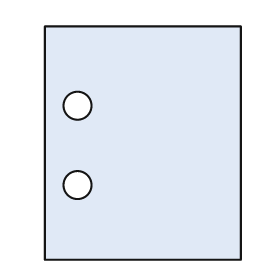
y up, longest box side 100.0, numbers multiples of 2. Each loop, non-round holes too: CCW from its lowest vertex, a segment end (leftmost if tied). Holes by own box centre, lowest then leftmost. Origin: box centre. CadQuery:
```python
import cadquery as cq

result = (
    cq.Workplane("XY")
    .moveTo(-42.0, -50.0)
    .lineTo(42.0, -50.0)
    .lineTo(42.0, 50.0)
    .lineTo(-42.0, 50.0)
    .close()
    .moveTo(-28.0, -18.0)
    .circle(6.0)
    .moveTo(-28.0, 16.0)
    .circle(6.0)
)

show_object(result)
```